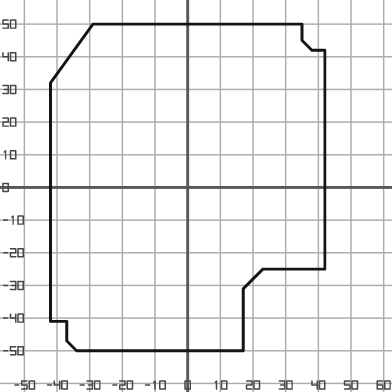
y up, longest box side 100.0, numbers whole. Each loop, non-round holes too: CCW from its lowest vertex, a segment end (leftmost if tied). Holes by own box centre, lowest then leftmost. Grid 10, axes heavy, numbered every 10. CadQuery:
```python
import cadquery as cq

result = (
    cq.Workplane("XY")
    .moveTo(-34.0, -50.0)
    .lineTo(17.0, -50.0)
    .lineTo(17.0, -31.0)
    .lineTo(23.0, -25.0)
    .lineTo(42.0, -25.0)
    .lineTo(42.0, 42.0)
    .lineTo(38.0, 42.0)
    .lineTo(35.0, 45.0)
    .lineTo(35.0, 50.0)
    .lineTo(-29.0, 50.0)
    .lineTo(-42.0, 32.0)
    .lineTo(-42.0, -41.0)
    .lineTo(-37.0, -41.0)
    .lineTo(-37.0, -47.0)
    .close()
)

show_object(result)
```